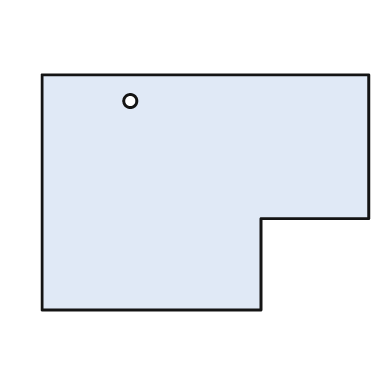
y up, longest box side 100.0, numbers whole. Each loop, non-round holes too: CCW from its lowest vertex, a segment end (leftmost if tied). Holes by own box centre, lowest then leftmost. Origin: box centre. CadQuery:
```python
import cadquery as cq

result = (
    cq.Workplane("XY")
    .moveTo(-50.0, -36.0)
    .lineTo(17.0, -36.0)
    .lineTo(17.0, -8.0)
    .lineTo(50.0, -8.0)
    .lineTo(50.0, 36.0)
    .lineTo(-50.0, 36.0)
    .close()
    .moveTo(-23.0, 28.0)
    .circle(2.0)
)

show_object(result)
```